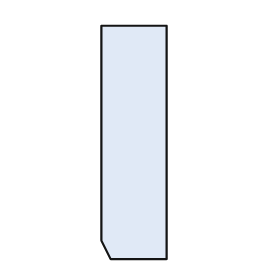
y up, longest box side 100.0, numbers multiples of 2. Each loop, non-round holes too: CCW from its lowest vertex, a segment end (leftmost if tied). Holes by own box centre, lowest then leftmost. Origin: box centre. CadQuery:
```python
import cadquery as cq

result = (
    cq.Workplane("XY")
    .moveTo(-10.0, -50.0)
    .lineTo(14.0, -50.0)
    .lineTo(14.0, 50.0)
    .lineTo(-14.0, 50.0)
    .lineTo(-14.0, -42.0)
    .close()
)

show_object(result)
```